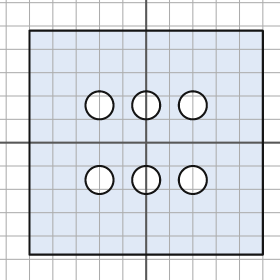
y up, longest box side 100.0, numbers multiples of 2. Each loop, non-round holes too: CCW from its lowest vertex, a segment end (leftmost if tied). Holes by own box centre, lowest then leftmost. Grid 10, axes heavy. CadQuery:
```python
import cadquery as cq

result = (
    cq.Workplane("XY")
    .moveTo(-50.0, -48.0)
    .lineTo(50.0, -48.0)
    .lineTo(50.0, 48.0)
    .lineTo(-50.0, 48.0)
    .close()
    .moveTo(-20.0, -16.0)
    .circle(6.0)
    .moveTo(0.0, -16.0)
    .circle(6.0)
    .moveTo(20.0, -16.0)
    .circle(6.0)
    .moveTo(-20.0, 16.0)
    .circle(6.0)
    .moveTo(0.0, 16.0)
    .circle(6.0)
    .moveTo(20.0, 16.0)
    .circle(6.0)
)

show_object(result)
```